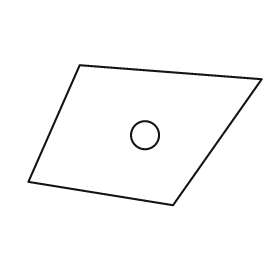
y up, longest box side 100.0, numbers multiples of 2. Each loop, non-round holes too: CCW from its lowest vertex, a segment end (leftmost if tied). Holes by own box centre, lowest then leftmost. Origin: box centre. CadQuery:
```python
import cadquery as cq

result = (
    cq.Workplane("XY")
    .moveTo(12.0, -30.0)
    .lineTo(50.0, 24.0)
    .lineTo(-28.0, 30.0)
    .lineTo(-50.0, -20.0)
    .close()
    .moveTo(0.0, 0.0)
    .circle(6.0)
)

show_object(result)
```